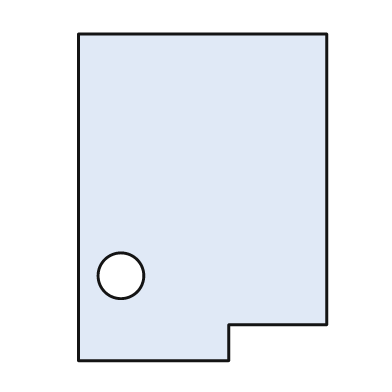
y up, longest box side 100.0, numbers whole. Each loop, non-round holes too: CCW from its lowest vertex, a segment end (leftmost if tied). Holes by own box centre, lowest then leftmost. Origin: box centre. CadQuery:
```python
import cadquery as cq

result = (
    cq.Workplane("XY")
    .moveTo(-38.0, -50.0)
    .lineTo(8.0, -50.0)
    .lineTo(8.0, -39.0)
    .lineTo(38.0, -39.0)
    .lineTo(38.0, 50.0)
    .lineTo(-38.0, 50.0)
    .close()
    .moveTo(-25.0, -24.0)
    .circle(7.0)
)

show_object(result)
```